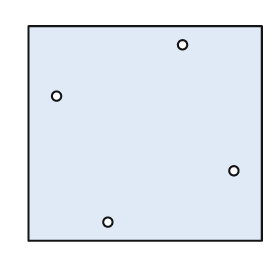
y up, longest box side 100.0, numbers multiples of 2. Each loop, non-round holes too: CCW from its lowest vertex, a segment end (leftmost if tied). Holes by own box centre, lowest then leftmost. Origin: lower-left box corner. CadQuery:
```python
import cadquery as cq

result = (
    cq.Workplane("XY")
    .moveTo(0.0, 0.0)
    .lineTo(100.0, 0.0)
    .lineTo(100.0, 92.0)
    .lineTo(0.0, 92.0)
    .close()
    .moveTo(34.0, 8.0)
    .circle(2.0)
    .moveTo(88.0, 30.0)
    .circle(2.0)
    .moveTo(12.0, 62.0)
    .circle(2.0)
    .moveTo(66.0, 84.0)
    .circle(2.0)
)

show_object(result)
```